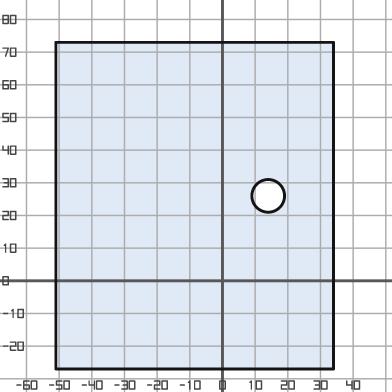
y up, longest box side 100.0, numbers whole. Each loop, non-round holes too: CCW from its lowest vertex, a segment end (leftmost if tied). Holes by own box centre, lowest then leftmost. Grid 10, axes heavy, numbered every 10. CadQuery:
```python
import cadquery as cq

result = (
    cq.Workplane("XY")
    .moveTo(-51.0, -27.0)
    .lineTo(34.0, -27.0)
    .lineTo(34.0, 73.0)
    .lineTo(-51.0, 73.0)
    .close()
    .moveTo(14.0, 26.0)
    .circle(5.0)
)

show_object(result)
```